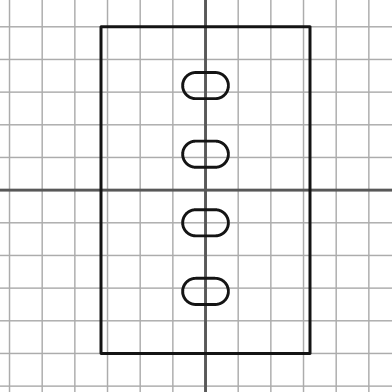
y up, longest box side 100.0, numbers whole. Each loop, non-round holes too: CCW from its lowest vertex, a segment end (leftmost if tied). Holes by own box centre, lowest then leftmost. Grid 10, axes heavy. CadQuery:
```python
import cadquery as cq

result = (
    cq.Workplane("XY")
    .moveTo(-32.0, -50.0)
    .lineTo(32.0, -50.0)
    .lineTo(32.0, 50.0)
    .lineTo(-32.0, 50.0)
    .close()
    .moveTo(-3.0, -35.0)
    .lineTo(3.0, -35.0)
    .threePointArc((7.0, -31.0), (3.0, -27.0))
    .lineTo(-3.0, -27.0)
    .threePointArc((-7.0, -31.0), (-3.0, -35.0))
    .close()
    .moveTo(-3.0, -14.0)
    .lineTo(3.0, -14.0)
    .threePointArc((7.0, -10.0), (3.0, -6.0))
    .lineTo(-3.0, -6.0)
    .threePointArc((-7.0, -10.0), (-3.0, -14.0))
    .close()
    .moveTo(-3.0, 7.0)
    .lineTo(3.0, 7.0)
    .threePointArc((7.0, 11.0), (3.0, 15.0))
    .lineTo(-3.0, 15.0)
    .threePointArc((-7.0, 11.0), (-3.0, 7.0))
    .close()
    .moveTo(-3.0, 28.0)
    .lineTo(3.0, 28.0)
    .threePointArc((7.0, 32.0), (3.0, 36.0))
    .lineTo(-3.0, 36.0)
    .threePointArc((-7.0, 32.0), (-3.0, 28.0))
    .close()
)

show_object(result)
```